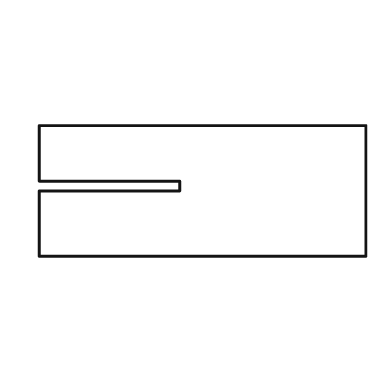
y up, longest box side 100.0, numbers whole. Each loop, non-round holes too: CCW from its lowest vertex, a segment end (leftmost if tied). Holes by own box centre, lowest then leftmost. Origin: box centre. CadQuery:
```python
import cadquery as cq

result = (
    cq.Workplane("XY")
    .moveTo(-50.0, -20.0)
    .lineTo(50.0, -20.0)
    .lineTo(50.0, 20.0)
    .lineTo(-50.0, 20.0)
    .lineTo(-50.0, 3.0)
    .lineTo(-7.0, 3.0)
    .lineTo(-7.0, 0.0)
    .lineTo(-50.0, 0.0)
    .close()
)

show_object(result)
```